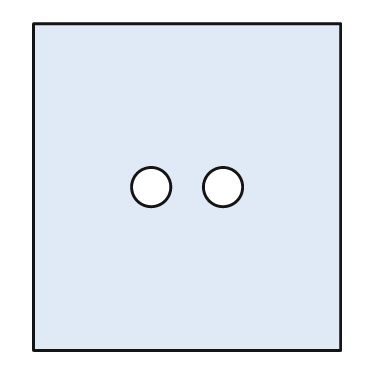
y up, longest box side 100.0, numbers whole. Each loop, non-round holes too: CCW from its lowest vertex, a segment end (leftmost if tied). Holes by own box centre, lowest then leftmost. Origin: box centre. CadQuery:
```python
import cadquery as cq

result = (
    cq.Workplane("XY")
    .moveTo(-47.0, -50.0)
    .lineTo(47.0, -50.0)
    .lineTo(47.0, 50.0)
    .lineTo(-47.0, 50.0)
    .close()
    .moveTo(-11.0, 0.0)
    .circle(6.0)
    .moveTo(11.0, 0.0)
    .circle(6.0)
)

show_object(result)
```